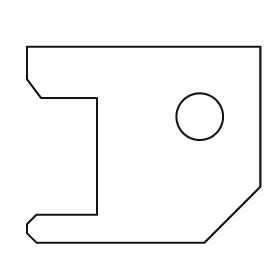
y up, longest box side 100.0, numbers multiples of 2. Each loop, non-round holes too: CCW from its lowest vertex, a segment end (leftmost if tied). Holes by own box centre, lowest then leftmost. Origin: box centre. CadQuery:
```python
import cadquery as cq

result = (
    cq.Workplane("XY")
    .moveTo(-46.0, -42.0)
    .lineTo(26.0, -42.0)
    .lineTo(50.0, -18.0)
    .lineTo(50.0, 42.0)
    .lineTo(-50.0, 42.0)
    .lineTo(-50.0, 28.0)
    .lineTo(-44.0, 20.0)
    .lineTo(-20.0, 20.0)
    .lineTo(-20.0, -30.0)
    .lineTo(-46.0, -30.0)
    .lineTo(-50.0, -34.0)
    .lineTo(-50.0, -38.0)
    .close()
    .moveTo(24.0, 12.0)
    .circle(10.0)
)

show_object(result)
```